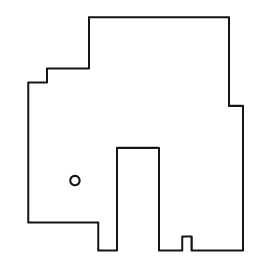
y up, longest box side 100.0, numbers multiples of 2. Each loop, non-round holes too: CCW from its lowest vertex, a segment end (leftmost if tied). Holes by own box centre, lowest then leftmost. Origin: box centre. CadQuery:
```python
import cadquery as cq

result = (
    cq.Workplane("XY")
    .moveTo(-16.0, -50.0)
    .lineTo(-8.0, -50.0)
    .lineTo(-8.0, -6.0)
    .lineTo(10.0, -6.0)
    .lineTo(10.0, -50.0)
    .lineTo(20.0, -50.0)
    .lineTo(20.0, -44.0)
    .lineTo(24.0, -44.0)
    .lineTo(24.0, -50.0)
    .lineTo(46.0, -50.0)
    .lineTo(46.0, 12.0)
    .lineTo(40.0, 12.0)
    .lineTo(40.0, 50.0)
    .lineTo(-20.0, 50.0)
    .lineTo(-20.0, 28.0)
    .lineTo(-38.0, 28.0)
    .lineTo(-38.0, 22.0)
    .lineTo(-46.0, 22.0)
    .lineTo(-46.0, -38.0)
    .lineTo(-16.0, -38.0)
    .close()
    .moveTo(-26.0, -20.0)
    .circle(2.0)
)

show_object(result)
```